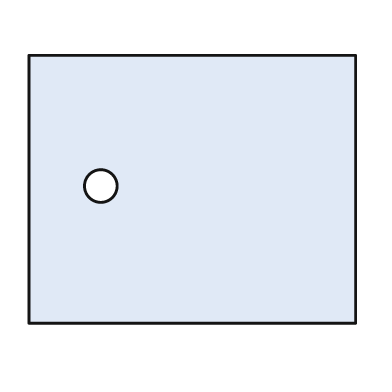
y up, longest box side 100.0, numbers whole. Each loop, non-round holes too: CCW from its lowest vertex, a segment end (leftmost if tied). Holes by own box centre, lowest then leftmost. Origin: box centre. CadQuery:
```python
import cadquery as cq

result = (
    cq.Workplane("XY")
    .moveTo(-50.0, -41.0)
    .lineTo(50.0, -41.0)
    .lineTo(50.0, 41.0)
    .lineTo(-50.0, 41.0)
    .close()
    .moveTo(-28.0, 1.0)
    .circle(5.0)
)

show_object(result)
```